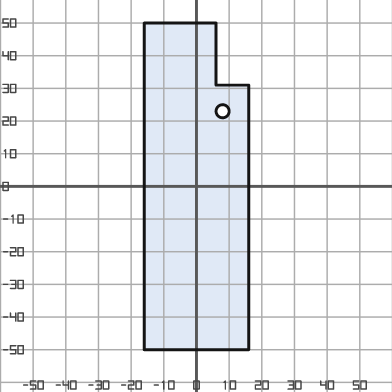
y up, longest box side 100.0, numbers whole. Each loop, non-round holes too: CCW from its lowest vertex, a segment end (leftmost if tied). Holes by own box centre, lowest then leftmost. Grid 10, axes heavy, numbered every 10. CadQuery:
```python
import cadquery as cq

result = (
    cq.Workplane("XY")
    .moveTo(-16.0, -50.0)
    .lineTo(16.0, -50.0)
    .lineTo(16.0, 31.0)
    .lineTo(6.0, 31.0)
    .lineTo(6.0, 50.0)
    .lineTo(-16.0, 50.0)
    .close()
    .moveTo(8.0, 23.0)
    .circle(2.0)
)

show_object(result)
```